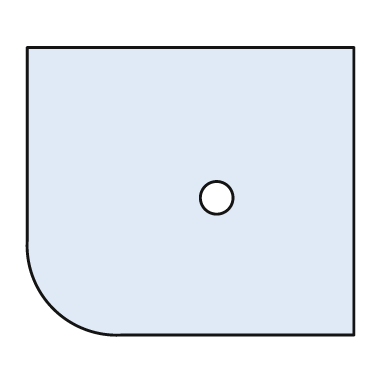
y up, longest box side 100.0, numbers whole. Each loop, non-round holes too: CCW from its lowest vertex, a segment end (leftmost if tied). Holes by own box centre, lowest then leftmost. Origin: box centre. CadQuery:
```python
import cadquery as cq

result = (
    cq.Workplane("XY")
    .moveTo(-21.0, -44.0)
    .lineTo(50.0, -44.0)
    .lineTo(50.0, 44.0)
    .lineTo(-50.0, 44.0)
    .lineTo(-50.0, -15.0)
    .threePointArc((-42.0, -36.0), (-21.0, -44.0))
    .close()
    .moveTo(8.0, -2.0)
    .circle(5.0)
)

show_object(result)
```